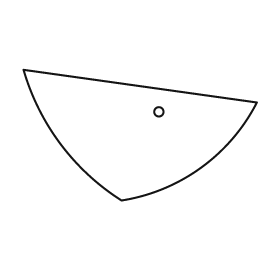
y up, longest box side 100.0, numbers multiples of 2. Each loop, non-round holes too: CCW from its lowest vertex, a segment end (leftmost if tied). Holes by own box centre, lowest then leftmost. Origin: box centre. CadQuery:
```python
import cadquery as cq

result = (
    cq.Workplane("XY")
    .moveTo(-8.0, -28.0)
    .threePointArc((26.0, -14.0), (50.0, 14.0))
    .lineTo(-50.0, 28.0)
    .threePointArc((-34.0, -4.0), (-8.0, -28.0))
    .close()
    .moveTo(8.0, 10.0)
    .circle(2.0)
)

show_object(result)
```